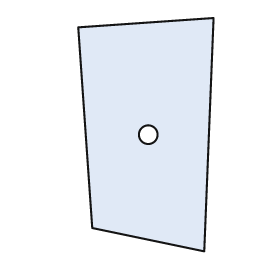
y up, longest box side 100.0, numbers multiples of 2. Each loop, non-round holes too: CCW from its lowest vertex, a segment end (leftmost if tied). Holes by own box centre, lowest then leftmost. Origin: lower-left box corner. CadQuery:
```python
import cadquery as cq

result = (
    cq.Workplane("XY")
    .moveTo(54.0, 0.0)
    .lineTo(58.0, 100.0)
    .lineTo(0.0, 96.0)
    .lineTo(6.0, 10.0)
    .close()
    .moveTo(30.0, 50.0)
    .circle(4.0)
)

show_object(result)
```